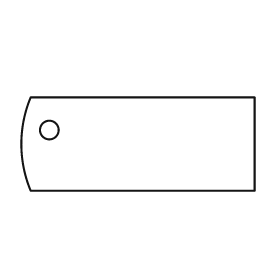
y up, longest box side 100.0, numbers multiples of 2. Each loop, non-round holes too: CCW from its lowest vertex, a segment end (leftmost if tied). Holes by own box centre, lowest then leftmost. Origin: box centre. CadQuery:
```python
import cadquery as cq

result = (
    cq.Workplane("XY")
    .moveTo(-46.0, -20.0)
    .lineTo(50.0, -20.0)
    .lineTo(50.0, 20.0)
    .lineTo(-46.0, 20.0)
    .threePointArc((-50.0, 0.0), (-46.0, -20.0))
    .close()
    .moveTo(-38.0, 6.0)
    .circle(4.0)
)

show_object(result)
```